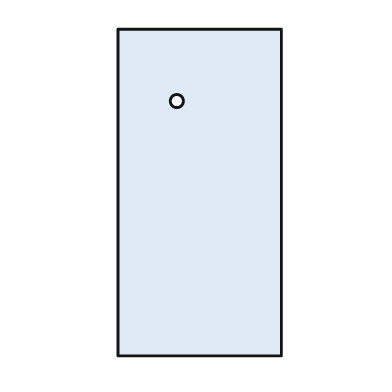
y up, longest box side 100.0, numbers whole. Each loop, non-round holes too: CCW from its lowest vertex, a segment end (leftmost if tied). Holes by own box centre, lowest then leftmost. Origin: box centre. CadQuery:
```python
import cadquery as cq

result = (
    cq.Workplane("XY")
    .moveTo(-25.0, -50.0)
    .lineTo(25.0, -50.0)
    .lineTo(25.0, 50.0)
    .lineTo(-25.0, 50.0)
    .close()
    .moveTo(-7.0, 28.0)
    .circle(2.0)
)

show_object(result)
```